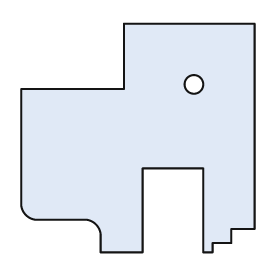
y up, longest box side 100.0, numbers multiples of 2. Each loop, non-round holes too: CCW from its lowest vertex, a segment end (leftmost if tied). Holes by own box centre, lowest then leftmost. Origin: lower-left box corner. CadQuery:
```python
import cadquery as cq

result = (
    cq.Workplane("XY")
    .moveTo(34.0, 0.0)
    .lineTo(52.0, 0.0)
    .lineTo(52.0, 36.0)
    .lineTo(78.0, 36.0)
    .lineTo(78.0, 0.0)
    .lineTo(82.0, 0.0)
    .lineTo(82.0, 4.0)
    .lineTo(90.0, 4.0)
    .lineTo(90.0, 10.0)
    .lineTo(100.0, 10.0)
    .lineTo(100.0, 98.0)
    .lineTo(44.0, 98.0)
    .lineTo(44.0, 70.0)
    .lineTo(0.0, 70.0)
    .lineTo(0.0, 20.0)
    .threePointArc((2.0, 16.0), (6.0, 14.0))
    .lineTo(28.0, 14.0)
    .threePointArc((32.0, 12.0), (34.0, 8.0))
    .close()
    .moveTo(74.0, 72.0)
    .circle(4.0)
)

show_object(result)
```